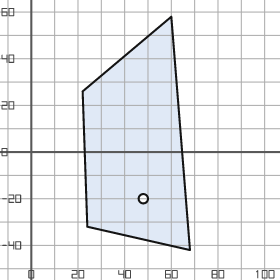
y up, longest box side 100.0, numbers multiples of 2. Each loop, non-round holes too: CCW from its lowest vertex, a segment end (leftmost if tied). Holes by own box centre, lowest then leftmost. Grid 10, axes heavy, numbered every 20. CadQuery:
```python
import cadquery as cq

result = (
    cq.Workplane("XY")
    .moveTo(68.0, -42.0)
    .lineTo(60.0, 58.0)
    .lineTo(22.0, 26.0)
    .lineTo(24.0, -32.0)
    .close()
    .moveTo(48.0, -20.0)
    .circle(2.0)
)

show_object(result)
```